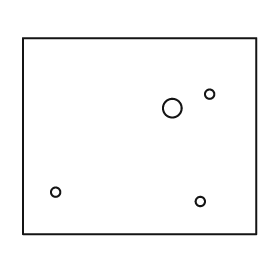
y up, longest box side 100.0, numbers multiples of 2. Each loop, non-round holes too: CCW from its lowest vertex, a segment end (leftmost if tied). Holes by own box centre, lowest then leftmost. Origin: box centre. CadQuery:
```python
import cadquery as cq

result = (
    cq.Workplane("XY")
    .moveTo(-50.0, -42.0)
    .lineTo(50.0, -42.0)
    .lineTo(50.0, 42.0)
    .lineTo(-50.0, 42.0)
    .close()
    .moveTo(26.0, -28.0)
    .circle(2.0)
    .moveTo(-36.0, -24.0)
    .circle(2.0)
    .moveTo(14.0, 12.0)
    .circle(4.0)
    .moveTo(30.0, 18.0)
    .circle(2.0)
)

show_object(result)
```